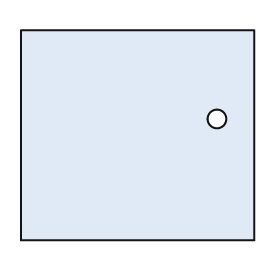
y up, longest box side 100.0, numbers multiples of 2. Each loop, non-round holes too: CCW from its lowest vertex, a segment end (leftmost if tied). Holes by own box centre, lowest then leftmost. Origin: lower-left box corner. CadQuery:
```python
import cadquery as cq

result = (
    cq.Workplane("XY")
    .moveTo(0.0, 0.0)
    .lineTo(100.0, 0.0)
    .lineTo(100.0, 90.0)
    .lineTo(0.0, 90.0)
    .close()
    .moveTo(84.0, 52.0)
    .circle(4.0)
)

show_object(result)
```